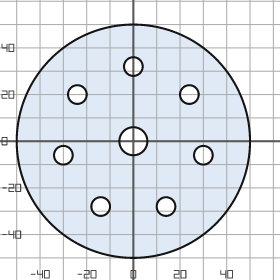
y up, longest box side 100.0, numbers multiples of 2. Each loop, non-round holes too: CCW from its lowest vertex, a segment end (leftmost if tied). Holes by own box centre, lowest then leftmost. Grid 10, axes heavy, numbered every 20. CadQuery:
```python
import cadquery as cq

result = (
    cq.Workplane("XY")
    .moveTo(0.0, 0.0)
    .circle(50.0)
    .moveTo(-14.0, -28.0)
    .circle(4.0)
    .moveTo(14.0, -28.0)
    .circle(4.0)
    .moveTo(-30.0, -6.0)
    .circle(4.0)
    .moveTo(30.0, -6.0)
    .circle(4.0)
    .moveTo(0.0, 0.0)
    .circle(6.0)
    .moveTo(-24.0, 20.0)
    .circle(4.0)
    .moveTo(24.0, 20.0)
    .circle(4.0)
    .moveTo(0.0, 32.0)
    .circle(4.0)
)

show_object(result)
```